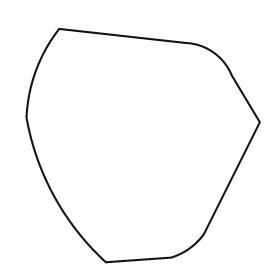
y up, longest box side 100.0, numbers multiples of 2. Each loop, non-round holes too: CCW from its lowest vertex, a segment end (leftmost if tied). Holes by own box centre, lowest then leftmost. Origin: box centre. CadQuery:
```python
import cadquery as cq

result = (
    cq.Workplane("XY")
    .moveTo(-16.0, -50.0)
    .lineTo(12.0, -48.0)
    .threePointArc((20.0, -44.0), (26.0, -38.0))
    .lineTo(50.0, 10.0)
    .lineTo(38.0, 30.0)
    .threePointArc((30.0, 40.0), (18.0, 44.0))
    .lineTo(-36.0, 50.0)
    .threePointArc((-46.0, 32.0), (-50.0, 12.0))
    .threePointArc((-38.0, -22.0), (-16.0, -50.0))
    .close()
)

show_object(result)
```